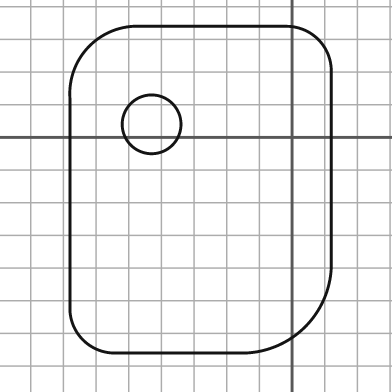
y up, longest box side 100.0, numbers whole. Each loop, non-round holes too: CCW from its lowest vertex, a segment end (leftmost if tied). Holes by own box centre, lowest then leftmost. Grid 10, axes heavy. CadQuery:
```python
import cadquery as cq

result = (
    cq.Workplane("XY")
    .moveTo(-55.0, -66.0)
    .lineTo(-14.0, -66.0)
    .threePointArc((4.0, -58.0), (12.0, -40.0))
    .lineTo(12.0, 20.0)
    .threePointArc((8.0, 30.0), (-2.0, 34.0))
    .lineTo(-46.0, 34.0)
    .threePointArc((-62.0, 28.0), (-68.0, 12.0))
    .lineTo(-68.0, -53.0)
    .threePointArc((-64.0, -62.0), (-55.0, -66.0))
    .close()
    .moveTo(-43.0, 4.0)
    .circle(9.0)
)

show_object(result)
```